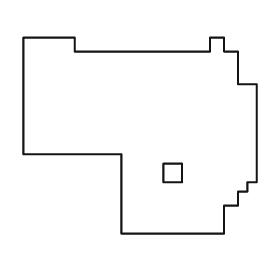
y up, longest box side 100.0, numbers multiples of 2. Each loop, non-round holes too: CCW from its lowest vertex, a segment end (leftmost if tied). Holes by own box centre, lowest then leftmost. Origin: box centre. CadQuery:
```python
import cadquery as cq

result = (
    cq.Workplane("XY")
    .moveTo(-8.0, -42.0)
    .lineTo(36.0, -42.0)
    .lineTo(36.0, -30.0)
    .lineTo(42.0, -30.0)
    .lineTo(42.0, -24.0)
    .lineTo(46.0, -24.0)
    .lineTo(46.0, -20.0)
    .lineTo(50.0, -20.0)
    .lineTo(50.0, 22.0)
    .lineTo(42.0, 22.0)
    .lineTo(42.0, 36.0)
    .lineTo(36.0, 36.0)
    .lineTo(36.0, 42.0)
    .lineTo(30.0, 42.0)
    .lineTo(30.0, 36.0)
    .lineTo(-28.0, 36.0)
    .lineTo(-28.0, 42.0)
    .lineTo(-50.0, 42.0)
    .lineTo(-50.0, -8.0)
    .lineTo(-8.0, -8.0)
    .close()
    .moveTo(10.0, -20.0)
    .lineTo(18.0, -20.0)
    .lineTo(18.0, -12.0)
    .lineTo(10.0, -12.0)
    .close()
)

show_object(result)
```